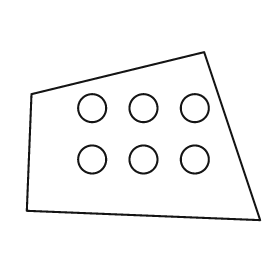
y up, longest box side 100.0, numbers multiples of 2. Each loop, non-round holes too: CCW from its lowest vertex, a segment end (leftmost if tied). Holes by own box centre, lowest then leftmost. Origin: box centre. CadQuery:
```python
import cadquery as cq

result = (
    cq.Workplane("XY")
    .moveTo(50.0, -36.0)
    .lineTo(26.0, 36.0)
    .lineTo(-48.0, 18.0)
    .lineTo(-50.0, -32.0)
    .close()
    .moveTo(-22.0, -10.0)
    .circle(6.0)
    .moveTo(0.0, -10.0)
    .circle(6.0)
    .moveTo(22.0, -10.0)
    .circle(6.0)
    .moveTo(-22.0, 12.0)
    .circle(6.0)
    .moveTo(0.0, 12.0)
    .circle(6.0)
    .moveTo(22.0, 12.0)
    .circle(6.0)
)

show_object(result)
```